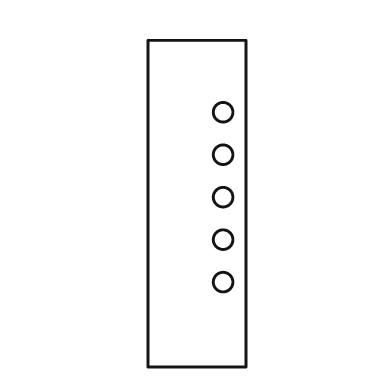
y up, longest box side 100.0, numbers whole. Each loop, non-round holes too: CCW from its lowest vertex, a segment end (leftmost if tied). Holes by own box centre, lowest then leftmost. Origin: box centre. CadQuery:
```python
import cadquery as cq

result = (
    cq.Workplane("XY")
    .moveTo(-15.0, -50.0)
    .lineTo(15.0, -50.0)
    .lineTo(15.0, 50.0)
    .lineTo(-15.0, 50.0)
    .close()
    .moveTo(8.0, -24.0)
    .circle(3.0)
    .moveTo(8.0, -11.0)
    .circle(3.0)
    .moveTo(8.0, 2.0)
    .circle(3.0)
    .moveTo(8.0, 15.0)
    .circle(3.0)
    .moveTo(8.0, 28.0)
    .circle(3.0)
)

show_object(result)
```